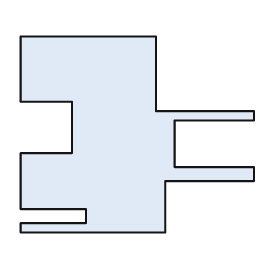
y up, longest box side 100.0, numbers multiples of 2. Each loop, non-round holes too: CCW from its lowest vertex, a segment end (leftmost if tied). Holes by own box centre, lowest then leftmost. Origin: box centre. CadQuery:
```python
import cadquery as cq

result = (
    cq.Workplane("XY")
    .moveTo(-50.0, -42.0)
    .lineTo(12.0, -42.0)
    .lineTo(12.0, -20.0)
    .lineTo(50.0, -20.0)
    .lineTo(50.0, -14.0)
    .lineTo(16.0, -14.0)
    .lineTo(16.0, 6.0)
    .lineTo(50.0, 6.0)
    .lineTo(50.0, 10.0)
    .lineTo(8.0, 10.0)
    .lineTo(8.0, 42.0)
    .lineTo(-50.0, 42.0)
    .lineTo(-50.0, 14.0)
    .lineTo(-28.0, 14.0)
    .lineTo(-28.0, -8.0)
    .lineTo(-50.0, -8.0)
    .lineTo(-50.0, -32.0)
    .lineTo(-22.0, -32.0)
    .lineTo(-22.0, -38.0)
    .lineTo(-50.0, -38.0)
    .close()
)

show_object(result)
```